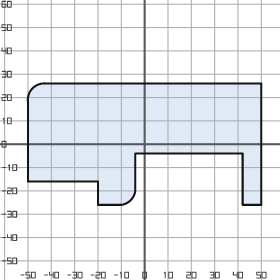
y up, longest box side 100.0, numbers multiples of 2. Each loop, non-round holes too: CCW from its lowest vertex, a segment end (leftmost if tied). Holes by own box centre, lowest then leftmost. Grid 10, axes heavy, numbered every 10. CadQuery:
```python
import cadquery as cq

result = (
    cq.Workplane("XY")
    .moveTo(-20.0, -26.0)
    .lineTo(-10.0, -26.0)
    .threePointArc((-6.0, -24.0), (-4.0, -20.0))
    .lineTo(-4.0, -4.0)
    .lineTo(42.0, -4.0)
    .lineTo(42.0, -26.0)
    .lineTo(50.0, -26.0)
    .lineTo(50.0, 26.0)
    .lineTo(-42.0, 26.0)
    .threePointArc((-48.0, 24.0), (-50.0, 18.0))
    .lineTo(-50.0, -16.0)
    .lineTo(-20.0, -16.0)
    .close()
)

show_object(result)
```